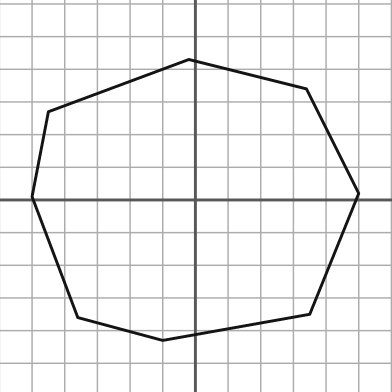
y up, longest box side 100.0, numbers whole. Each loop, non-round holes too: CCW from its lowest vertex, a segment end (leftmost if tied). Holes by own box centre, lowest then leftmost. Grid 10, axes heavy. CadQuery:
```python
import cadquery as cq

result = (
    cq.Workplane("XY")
    .moveTo(-10.0, -43.0)
    .lineTo(35.0, -35.0)
    .lineTo(50.0, 2.0)
    .lineTo(34.0, 34.0)
    .lineTo(-2.0, 43.0)
    .lineTo(-45.0, 27.0)
    .lineTo(-50.0, 1.0)
    .lineTo(-36.0, -36.0)
    .close()
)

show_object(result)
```